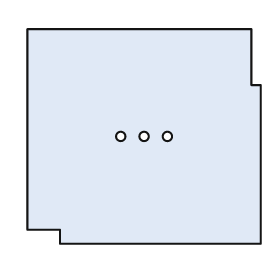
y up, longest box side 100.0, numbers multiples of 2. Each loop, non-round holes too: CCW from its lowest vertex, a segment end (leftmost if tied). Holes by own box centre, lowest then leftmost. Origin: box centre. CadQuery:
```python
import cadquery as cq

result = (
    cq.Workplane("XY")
    .moveTo(-36.0, -46.0)
    .lineTo(50.0, -46.0)
    .lineTo(50.0, 22.0)
    .lineTo(46.0, 22.0)
    .lineTo(46.0, 46.0)
    .lineTo(-50.0, 46.0)
    .lineTo(-50.0, -40.0)
    .lineTo(-36.0, -40.0)
    .close()
    .moveTo(-10.0, 0.0)
    .circle(2.0)
    .moveTo(0.0, 0.0)
    .circle(2.0)
    .moveTo(10.0, 0.0)
    .circle(2.0)
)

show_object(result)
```